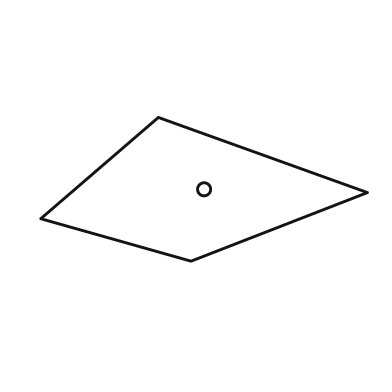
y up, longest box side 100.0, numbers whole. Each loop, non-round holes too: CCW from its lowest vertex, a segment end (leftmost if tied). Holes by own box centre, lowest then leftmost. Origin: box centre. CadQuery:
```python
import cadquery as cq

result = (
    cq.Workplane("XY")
    .moveTo(-4.0, -22.0)
    .lineTo(50.0, -1.0)
    .lineTo(-14.0, 22.0)
    .lineTo(-50.0, -9.0)
    .close()
    .moveTo(0.0, 0.0)
    .circle(2.0)
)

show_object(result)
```